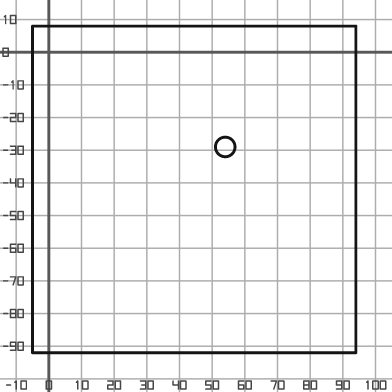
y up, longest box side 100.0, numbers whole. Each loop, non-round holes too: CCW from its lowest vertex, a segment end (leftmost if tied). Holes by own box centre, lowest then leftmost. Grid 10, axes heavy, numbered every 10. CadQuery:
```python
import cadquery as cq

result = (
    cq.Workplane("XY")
    .moveTo(-5.0, -92.0)
    .lineTo(94.0, -92.0)
    .lineTo(94.0, 8.0)
    .lineTo(-5.0, 8.0)
    .close()
    .moveTo(54.0, -29.0)
    .circle(3.0)
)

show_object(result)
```